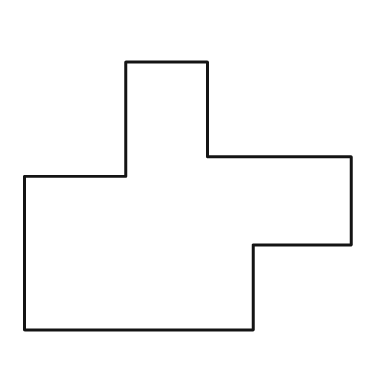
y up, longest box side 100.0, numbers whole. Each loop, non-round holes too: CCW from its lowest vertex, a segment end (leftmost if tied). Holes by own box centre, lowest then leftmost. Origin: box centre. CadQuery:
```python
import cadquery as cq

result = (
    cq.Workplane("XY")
    .moveTo(-50.0, -41.0)
    .lineTo(20.0, -41.0)
    .lineTo(20.0, -15.0)
    .lineTo(50.0, -15.0)
    .lineTo(50.0, 12.0)
    .lineTo(6.0, 12.0)
    .lineTo(6.0, 41.0)
    .lineTo(-19.0, 41.0)
    .lineTo(-19.0, 6.0)
    .lineTo(-50.0, 6.0)
    .close()
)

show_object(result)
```